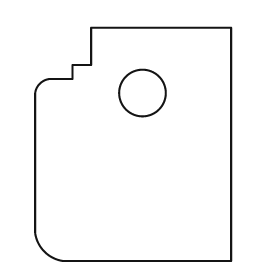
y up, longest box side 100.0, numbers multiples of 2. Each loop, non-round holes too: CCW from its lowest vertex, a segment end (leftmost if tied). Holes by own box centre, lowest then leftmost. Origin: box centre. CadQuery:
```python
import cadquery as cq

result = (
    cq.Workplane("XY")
    .moveTo(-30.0, -50.0)
    .lineTo(42.0, -50.0)
    .lineTo(42.0, 50.0)
    .lineTo(-18.0, 50.0)
    .lineTo(-18.0, 34.0)
    .lineTo(-26.0, 34.0)
    .lineTo(-26.0, 28.0)
    .lineTo(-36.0, 28.0)
    .threePointArc((-40.0, 26.0), (-42.0, 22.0))
    .lineTo(-42.0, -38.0)
    .threePointArc((-38.0, -46.0), (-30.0, -50.0))
    .close()
    .moveTo(4.0, 22.0)
    .circle(10.0)
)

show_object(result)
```